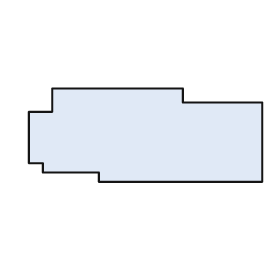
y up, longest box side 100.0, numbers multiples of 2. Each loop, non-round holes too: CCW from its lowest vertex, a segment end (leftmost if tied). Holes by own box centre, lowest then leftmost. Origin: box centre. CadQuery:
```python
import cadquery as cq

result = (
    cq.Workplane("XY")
    .moveTo(-20.0, -20.0)
    .lineTo(50.0, -20.0)
    .lineTo(50.0, 14.0)
    .lineTo(16.0, 14.0)
    .lineTo(16.0, 20.0)
    .lineTo(-40.0, 20.0)
    .lineTo(-40.0, 10.0)
    .lineTo(-50.0, 10.0)
    .lineTo(-50.0, -12.0)
    .lineTo(-44.0, -12.0)
    .lineTo(-44.0, -16.0)
    .lineTo(-20.0, -16.0)
    .close()
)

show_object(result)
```